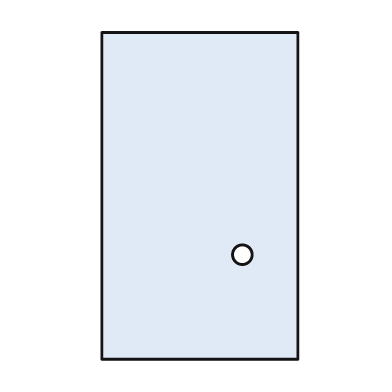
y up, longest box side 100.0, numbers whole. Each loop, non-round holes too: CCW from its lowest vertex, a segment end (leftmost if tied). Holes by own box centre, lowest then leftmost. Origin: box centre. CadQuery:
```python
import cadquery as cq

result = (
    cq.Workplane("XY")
    .moveTo(-30.0, -50.0)
    .lineTo(30.0, -50.0)
    .lineTo(30.0, 50.0)
    .lineTo(-30.0, 50.0)
    .close()
    .moveTo(13.0, -18.0)
    .circle(3.0)
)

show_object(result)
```